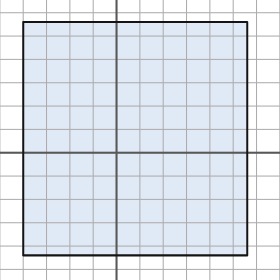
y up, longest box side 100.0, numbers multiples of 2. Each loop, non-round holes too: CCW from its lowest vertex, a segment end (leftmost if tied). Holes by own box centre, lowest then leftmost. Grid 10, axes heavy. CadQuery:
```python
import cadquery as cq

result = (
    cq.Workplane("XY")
    .moveTo(-40.0, -44.0)
    .lineTo(56.0, -44.0)
    .lineTo(56.0, 56.0)
    .lineTo(-40.0, 56.0)
    .close()
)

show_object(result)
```